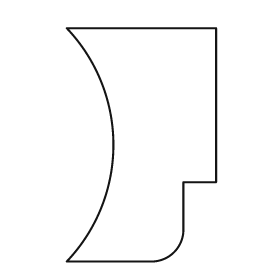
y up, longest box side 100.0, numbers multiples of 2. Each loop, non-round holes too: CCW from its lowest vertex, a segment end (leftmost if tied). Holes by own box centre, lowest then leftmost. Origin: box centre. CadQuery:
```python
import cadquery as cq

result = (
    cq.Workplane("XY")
    .moveTo(-32.0, -50.0)
    .lineTo(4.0, -50.0)
    .threePointArc((14.0, -46.0), (18.0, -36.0))
    .lineTo(18.0, -16.0)
    .lineTo(32.0, -16.0)
    .lineTo(32.0, 50.0)
    .lineTo(-32.0, 50.0)
    .threePointArc((-12.0, 0.0), (-32.0, -50.0))
    .close()
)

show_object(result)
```